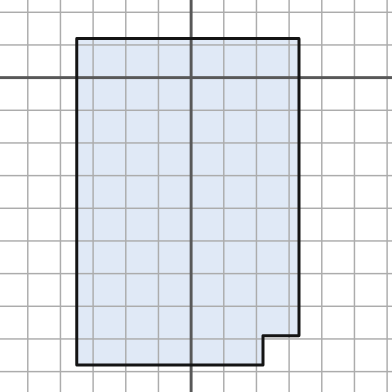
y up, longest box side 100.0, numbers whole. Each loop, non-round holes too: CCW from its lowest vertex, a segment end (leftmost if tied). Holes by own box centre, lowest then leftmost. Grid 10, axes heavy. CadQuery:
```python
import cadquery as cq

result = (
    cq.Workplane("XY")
    .moveTo(-35.0, -88.0)
    .lineTo(22.0, -88.0)
    .lineTo(22.0, -79.0)
    .lineTo(33.0, -79.0)
    .lineTo(33.0, 12.0)
    .lineTo(-35.0, 12.0)
    .close()
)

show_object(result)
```